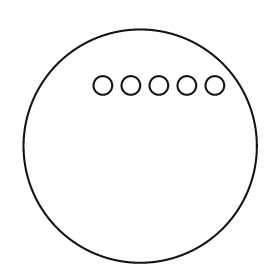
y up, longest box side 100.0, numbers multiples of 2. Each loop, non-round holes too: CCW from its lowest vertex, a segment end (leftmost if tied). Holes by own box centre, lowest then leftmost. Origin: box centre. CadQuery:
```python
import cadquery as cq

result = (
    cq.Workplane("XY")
    .moveTo(0.0, 0.0)
    .circle(50.0)
    .moveTo(-16.0, 26.0)
    .circle(4.0)
    .moveTo(-4.0, 26.0)
    .circle(4.0)
    .moveTo(8.0, 26.0)
    .circle(4.0)
    .moveTo(20.0, 26.0)
    .circle(4.0)
    .moveTo(32.0, 26.0)
    .circle(4.0)
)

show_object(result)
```